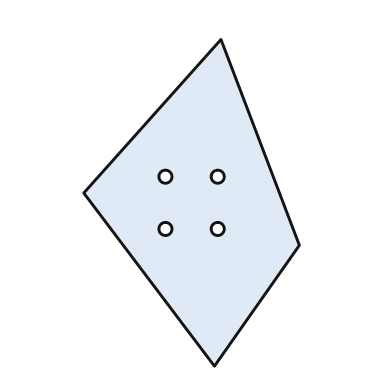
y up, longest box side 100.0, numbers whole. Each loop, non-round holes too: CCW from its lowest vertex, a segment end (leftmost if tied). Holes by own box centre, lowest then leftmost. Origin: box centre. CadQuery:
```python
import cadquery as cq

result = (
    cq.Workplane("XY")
    .moveTo(7.0, -50.0)
    .lineTo(33.0, -13.0)
    .lineTo(9.0, 50.0)
    .lineTo(-33.0, 3.0)
    .close()
    .moveTo(-8.0, -8.0)
    .circle(2.0)
    .moveTo(8.0, -8.0)
    .circle(2.0)
    .moveTo(-8.0, 8.0)
    .circle(2.0)
    .moveTo(8.0, 8.0)
    .circle(2.0)
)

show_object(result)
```